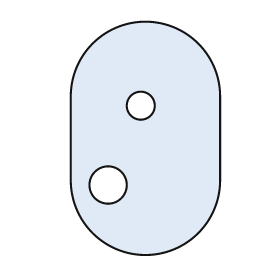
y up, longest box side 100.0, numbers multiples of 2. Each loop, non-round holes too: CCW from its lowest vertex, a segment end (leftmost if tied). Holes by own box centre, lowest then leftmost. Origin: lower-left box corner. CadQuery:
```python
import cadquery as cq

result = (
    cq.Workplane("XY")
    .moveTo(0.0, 32.0)
    .threePointArc((32.0, 0.0), (64.0, 32.0))
    .lineTo(64.0, 68.0)
    .threePointArc((32.0, 100.0), (0.0, 68.0))
    .close()
    .moveTo(16.0, 30.0)
    .circle(8.0)
    .moveTo(30.0, 64.0)
    .circle(6.0)
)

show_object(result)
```